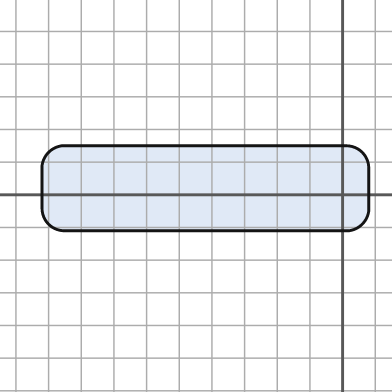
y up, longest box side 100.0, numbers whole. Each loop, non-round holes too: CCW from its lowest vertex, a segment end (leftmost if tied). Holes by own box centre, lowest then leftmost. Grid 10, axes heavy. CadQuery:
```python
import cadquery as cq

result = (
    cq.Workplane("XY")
    .moveTo(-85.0, -11.0)
    .lineTo(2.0, -11.0)
    .threePointArc((6.0, -9.0), (8.0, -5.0))
    .lineTo(8.0, 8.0)
    .threePointArc((6.0, 13.0), (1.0, 15.0))
    .lineTo(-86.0, 15.0)
    .threePointArc((-90.0, 13.0), (-92.0, 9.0))
    .lineTo(-92.0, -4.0)
    .threePointArc((-90.0, -9.0), (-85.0, -11.0))
    .close()
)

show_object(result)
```